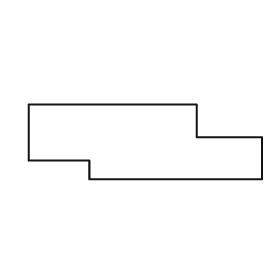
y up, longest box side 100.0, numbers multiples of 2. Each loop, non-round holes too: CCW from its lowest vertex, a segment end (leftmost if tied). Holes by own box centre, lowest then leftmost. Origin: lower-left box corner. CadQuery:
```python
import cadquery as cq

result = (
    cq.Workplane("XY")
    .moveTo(26.0, 0.0)
    .lineTo(100.0, 0.0)
    .lineTo(100.0, 18.0)
    .lineTo(72.0, 18.0)
    .lineTo(72.0, 32.0)
    .lineTo(0.0, 32.0)
    .lineTo(0.0, 8.0)
    .lineTo(26.0, 8.0)
    .close()
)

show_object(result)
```